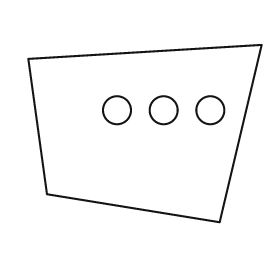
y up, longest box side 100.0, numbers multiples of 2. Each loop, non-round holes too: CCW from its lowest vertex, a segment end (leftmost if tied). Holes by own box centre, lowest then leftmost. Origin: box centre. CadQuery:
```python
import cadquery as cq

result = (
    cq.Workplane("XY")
    .moveTo(32.0, -38.0)
    .lineTo(50.0, 38.0)
    .lineTo(-50.0, 32.0)
    .lineTo(-42.0, -26.0)
    .close()
    .moveTo(-12.0, 10.0)
    .circle(6.0)
    .moveTo(8.0, 10.0)
    .circle(6.0)
    .moveTo(28.0, 10.0)
    .circle(6.0)
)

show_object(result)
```